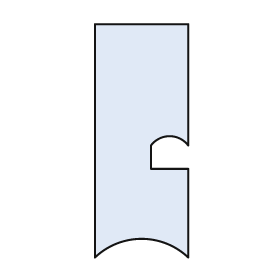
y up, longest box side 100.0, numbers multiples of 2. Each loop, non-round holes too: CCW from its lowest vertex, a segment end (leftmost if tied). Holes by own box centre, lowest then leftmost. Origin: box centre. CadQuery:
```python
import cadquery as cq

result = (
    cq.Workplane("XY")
    .moveTo(-20.0, -50.0)
    .threePointArc((0.0, -42.0), (20.0, -50.0))
    .lineTo(20.0, -12.0)
    .lineTo(4.0, -12.0)
    .lineTo(4.0, -2.0)
    .threePointArc((12.0, 2.0), (20.0, -2.0))
    .lineTo(20.0, 50.0)
    .lineTo(-20.0, 50.0)
    .close()
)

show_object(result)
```